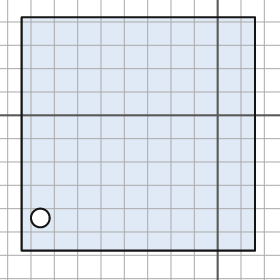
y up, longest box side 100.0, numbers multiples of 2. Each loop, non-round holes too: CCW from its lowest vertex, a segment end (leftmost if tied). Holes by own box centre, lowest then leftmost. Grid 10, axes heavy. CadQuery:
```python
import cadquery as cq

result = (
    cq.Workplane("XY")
    .moveTo(-84.0, -58.0)
    .lineTo(16.0, -58.0)
    .lineTo(16.0, 42.0)
    .lineTo(-84.0, 42.0)
    .close()
    .moveTo(-76.0, -44.0)
    .circle(4.0)
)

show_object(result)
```